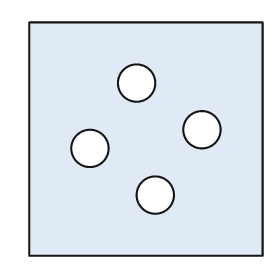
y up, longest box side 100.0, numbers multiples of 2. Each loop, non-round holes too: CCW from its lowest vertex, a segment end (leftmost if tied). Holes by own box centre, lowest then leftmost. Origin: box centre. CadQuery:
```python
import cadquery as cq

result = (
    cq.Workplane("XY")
    .moveTo(-50.0, -50.0)
    .lineTo(50.0, -50.0)
    .lineTo(50.0, 50.0)
    .lineTo(-50.0, 50.0)
    .close()
    .moveTo(4.0, -24.0)
    .circle(8.0)
    .moveTo(-24.0, -4.0)
    .circle(8.0)
    .moveTo(24.0, 4.0)
    .circle(8.0)
    .moveTo(-4.0, 24.0)
    .circle(8.0)
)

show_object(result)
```